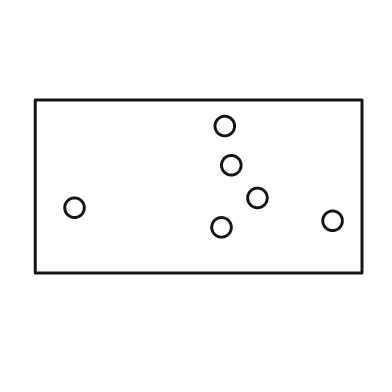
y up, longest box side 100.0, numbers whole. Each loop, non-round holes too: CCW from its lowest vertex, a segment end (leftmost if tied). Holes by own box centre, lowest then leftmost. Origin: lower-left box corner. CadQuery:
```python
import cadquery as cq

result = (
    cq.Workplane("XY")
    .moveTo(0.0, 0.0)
    .lineTo(100.0, 0.0)
    .lineTo(100.0, 53.0)
    .lineTo(0.0, 53.0)
    .close()
    .moveTo(57.0, 14.0)
    .circle(3.0)
    .moveTo(91.0, 16.0)
    .circle(3.0)
    .moveTo(12.0, 20.0)
    .circle(3.0)
    .moveTo(68.0, 23.0)
    .circle(3.0)
    .moveTo(60.0, 33.0)
    .circle(3.0)
    .moveTo(58.0, 45.0)
    .circle(3.0)
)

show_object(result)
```